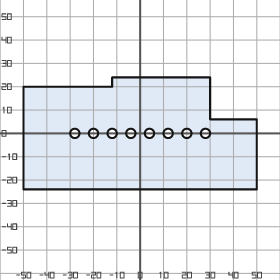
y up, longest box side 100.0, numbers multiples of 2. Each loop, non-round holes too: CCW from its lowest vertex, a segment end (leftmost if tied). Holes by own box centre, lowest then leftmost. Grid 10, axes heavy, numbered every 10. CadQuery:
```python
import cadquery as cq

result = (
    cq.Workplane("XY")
    .moveTo(-50.0, -24.0)
    .lineTo(50.0, -24.0)
    .lineTo(50.0, 6.0)
    .lineTo(30.0, 6.0)
    .lineTo(30.0, 24.0)
    .lineTo(-12.0, 24.0)
    .lineTo(-12.0, 20.0)
    .lineTo(-50.0, 20.0)
    .close()
    .moveTo(-28.0, 0.0)
    .circle(2.0)
    .moveTo(-20.0, 0.0)
    .circle(2.0)
    .moveTo(-12.0, 0.0)
    .circle(2.0)
    .moveTo(-4.0, 0.0)
    .circle(2.0)
    .moveTo(4.0, 0.0)
    .circle(2.0)
    .moveTo(12.0, 0.0)
    .circle(2.0)
    .moveTo(20.0, 0.0)
    .circle(2.0)
    .moveTo(28.0, 0.0)
    .circle(2.0)
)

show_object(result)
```